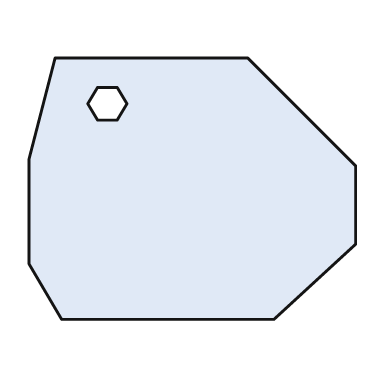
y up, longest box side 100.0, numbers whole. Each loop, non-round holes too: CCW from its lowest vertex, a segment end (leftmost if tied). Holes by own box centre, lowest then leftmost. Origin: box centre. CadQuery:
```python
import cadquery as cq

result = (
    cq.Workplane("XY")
    .moveTo(-40.0, -40.0)
    .lineTo(25.0, -40.0)
    .lineTo(50.0, -17.0)
    .lineTo(50.0, 7.0)
    .lineTo(17.0, 40.0)
    .lineTo(-42.0, 40.0)
    .lineTo(-50.0, 9.0)
    .lineTo(-50.0, -23.0)
    .close()
    .moveTo(-29.0, 21.0)
    .lineTo(-23.0, 21.0)
    .lineTo(-20.0, 26.0)
    .lineTo(-23.0, 31.0)
    .lineTo(-29.0, 31.0)
    .lineTo(-32.0, 26.0)
    .close()
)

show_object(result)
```